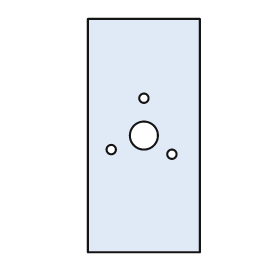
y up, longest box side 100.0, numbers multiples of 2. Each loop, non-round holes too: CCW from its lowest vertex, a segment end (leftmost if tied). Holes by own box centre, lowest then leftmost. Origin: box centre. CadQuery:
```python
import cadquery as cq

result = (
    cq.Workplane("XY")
    .moveTo(-24.0, -50.0)
    .lineTo(24.0, -50.0)
    .lineTo(24.0, 50.0)
    .lineTo(-24.0, 50.0)
    .close()
    .moveTo(12.0, -8.0)
    .circle(2.0)
    .moveTo(-14.0, -6.0)
    .circle(2.0)
    .moveTo(0.0, 0.0)
    .circle(6.0)
    .moveTo(0.0, 16.0)
    .circle(2.0)
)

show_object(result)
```